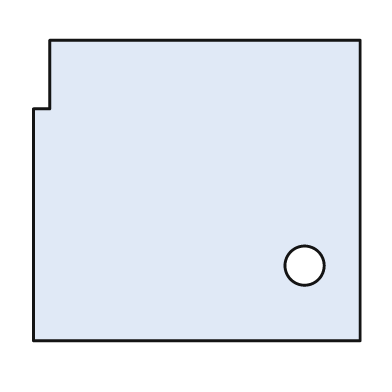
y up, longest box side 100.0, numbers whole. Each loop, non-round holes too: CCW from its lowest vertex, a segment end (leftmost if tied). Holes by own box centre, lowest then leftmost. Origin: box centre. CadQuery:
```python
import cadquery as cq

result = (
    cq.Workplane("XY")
    .moveTo(-50.0, -46.0)
    .lineTo(50.0, -46.0)
    .lineTo(50.0, 46.0)
    .lineTo(-45.0, 46.0)
    .lineTo(-45.0, 25.0)
    .lineTo(-50.0, 25.0)
    .close()
    .moveTo(33.0, -23.0)
    .circle(6.0)
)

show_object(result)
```